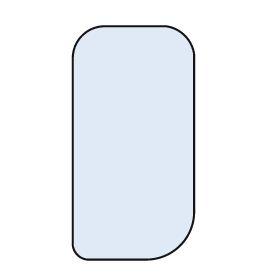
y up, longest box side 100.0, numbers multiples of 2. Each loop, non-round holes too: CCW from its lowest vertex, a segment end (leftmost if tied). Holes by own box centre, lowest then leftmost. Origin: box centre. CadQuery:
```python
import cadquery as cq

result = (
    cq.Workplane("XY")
    .moveTo(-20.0, -50.0)
    .lineTo(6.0, -50.0)
    .threePointArc((20.0, -44.0), (26.0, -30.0))
    .lineTo(26.0, 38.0)
    .threePointArc((22.0, 46.0), (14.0, 50.0))
    .lineTo(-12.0, 50.0)
    .threePointArc((-22.0, 46.0), (-26.0, 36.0))
    .lineTo(-26.0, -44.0)
    .threePointArc((-24.0, -48.0), (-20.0, -50.0))
    .close()
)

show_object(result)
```